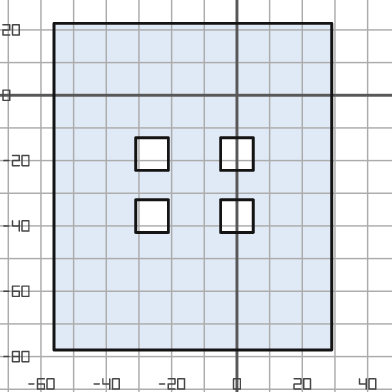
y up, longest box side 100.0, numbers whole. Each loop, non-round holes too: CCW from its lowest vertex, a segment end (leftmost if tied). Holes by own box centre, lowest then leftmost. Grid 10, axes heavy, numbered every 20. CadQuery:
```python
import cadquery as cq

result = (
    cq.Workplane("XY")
    .moveTo(-56.0, -78.0)
    .lineTo(29.0, -78.0)
    .lineTo(29.0, 22.0)
    .lineTo(-56.0, 22.0)
    .close()
    .moveTo(-31.0, -42.0)
    .lineTo(-21.0, -42.0)
    .lineTo(-21.0, -32.0)
    .lineTo(-31.0, -32.0)
    .close()
    .moveTo(-5.0, -42.0)
    .lineTo(5.0, -42.0)
    .lineTo(5.0, -32.0)
    .lineTo(-5.0, -32.0)
    .close()
    .moveTo(-31.0, -23.0)
    .lineTo(-21.0, -23.0)
    .lineTo(-21.0, -13.0)
    .lineTo(-31.0, -13.0)
    .close()
    .moveTo(-5.0, -23.0)
    .lineTo(5.0, -23.0)
    .lineTo(5.0, -13.0)
    .lineTo(-5.0, -13.0)
    .close()
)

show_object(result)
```